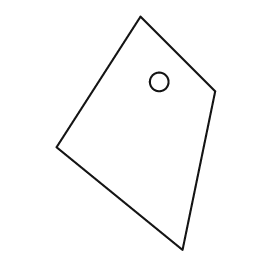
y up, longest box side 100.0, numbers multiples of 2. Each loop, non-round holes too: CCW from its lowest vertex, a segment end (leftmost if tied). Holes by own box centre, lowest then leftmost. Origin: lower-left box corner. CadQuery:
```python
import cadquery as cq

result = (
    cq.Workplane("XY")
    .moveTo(54.0, 0.0)
    .lineTo(68.0, 68.0)
    .lineTo(36.0, 100.0)
    .lineTo(0.0, 44.0)
    .close()
    .moveTo(44.0, 72.0)
    .circle(4.0)
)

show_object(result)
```